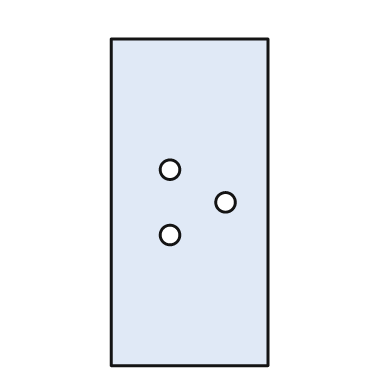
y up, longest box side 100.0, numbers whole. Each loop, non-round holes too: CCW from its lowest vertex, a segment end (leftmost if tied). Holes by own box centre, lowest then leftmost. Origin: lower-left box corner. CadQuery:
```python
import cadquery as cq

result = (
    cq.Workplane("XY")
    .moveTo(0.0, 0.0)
    .lineTo(48.0, 0.0)
    .lineTo(48.0, 100.0)
    .lineTo(0.0, 100.0)
    .close()
    .moveTo(18.0, 40.0)
    .circle(3.0)
    .moveTo(35.0, 50.0)
    .circle(3.0)
    .moveTo(18.0, 60.0)
    .circle(3.0)
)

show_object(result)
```